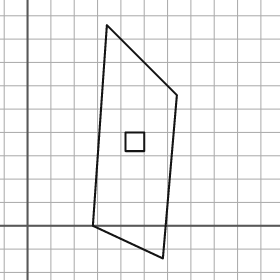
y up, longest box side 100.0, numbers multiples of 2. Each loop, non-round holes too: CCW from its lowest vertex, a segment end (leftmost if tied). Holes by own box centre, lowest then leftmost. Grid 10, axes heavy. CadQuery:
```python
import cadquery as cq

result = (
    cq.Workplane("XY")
    .moveTo(58.0, -14.0)
    .lineTo(64.0, 56.0)
    .lineTo(34.0, 86.0)
    .lineTo(28.0, 0.0)
    .close()
    .moveTo(42.0, 32.0)
    .lineTo(50.0, 32.0)
    .lineTo(50.0, 40.0)
    .lineTo(42.0, 40.0)
    .close()
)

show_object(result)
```